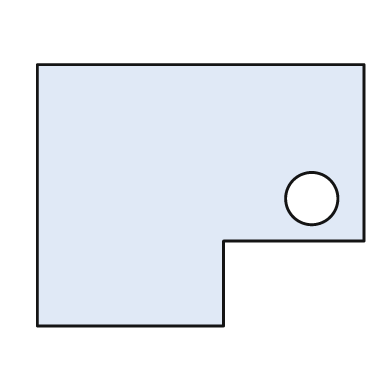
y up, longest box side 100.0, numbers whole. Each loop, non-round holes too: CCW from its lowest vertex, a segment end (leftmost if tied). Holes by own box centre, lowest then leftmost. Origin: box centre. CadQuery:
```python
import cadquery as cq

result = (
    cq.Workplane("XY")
    .moveTo(-50.0, -40.0)
    .lineTo(7.0, -40.0)
    .lineTo(7.0, -14.0)
    .lineTo(50.0, -14.0)
    .lineTo(50.0, 40.0)
    .lineTo(-50.0, 40.0)
    .close()
    .moveTo(34.0, -1.0)
    .circle(8.0)
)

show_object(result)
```